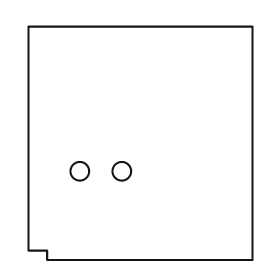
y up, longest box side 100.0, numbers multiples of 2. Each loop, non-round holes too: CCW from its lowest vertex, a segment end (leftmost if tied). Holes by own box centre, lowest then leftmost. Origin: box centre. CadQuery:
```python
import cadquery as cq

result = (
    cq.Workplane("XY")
    .moveTo(-40.0, -50.0)
    .lineTo(48.0, -50.0)
    .lineTo(48.0, 50.0)
    .lineTo(-48.0, 50.0)
    .lineTo(-48.0, -46.0)
    .lineTo(-40.0, -46.0)
    .close()
    .moveTo(-26.0, -12.0)
    .circle(4.0)
    .moveTo(-8.0, -12.0)
    .circle(4.0)
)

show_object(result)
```